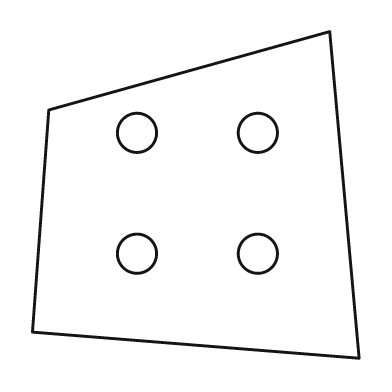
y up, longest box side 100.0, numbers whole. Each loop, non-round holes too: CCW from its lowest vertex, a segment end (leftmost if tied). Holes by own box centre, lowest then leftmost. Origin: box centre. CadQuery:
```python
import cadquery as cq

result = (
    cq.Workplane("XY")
    .moveTo(50.0, -50.0)
    .lineTo(41.0, 50.0)
    .lineTo(-45.0, 26.0)
    .lineTo(-50.0, -42.0)
    .close()
    .moveTo(-18.0, -18.0)
    .circle(6.0)
    .moveTo(19.0, -18.0)
    .circle(6.0)
    .moveTo(-18.0, 19.0)
    .circle(6.0)
    .moveTo(19.0, 19.0)
    .circle(6.0)
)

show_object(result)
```